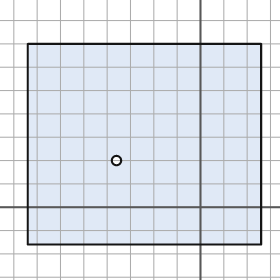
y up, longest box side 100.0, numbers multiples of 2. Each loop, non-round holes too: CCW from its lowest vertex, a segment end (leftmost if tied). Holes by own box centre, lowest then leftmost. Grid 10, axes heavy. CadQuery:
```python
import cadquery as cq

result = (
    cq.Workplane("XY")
    .moveTo(-74.0, -16.0)
    .lineTo(26.0, -16.0)
    .lineTo(26.0, 70.0)
    .lineTo(-74.0, 70.0)
    .close()
    .moveTo(-36.0, 20.0)
    .circle(2.0)
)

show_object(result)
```